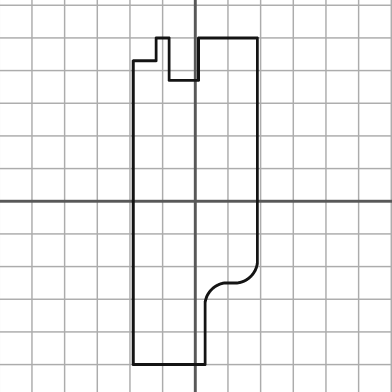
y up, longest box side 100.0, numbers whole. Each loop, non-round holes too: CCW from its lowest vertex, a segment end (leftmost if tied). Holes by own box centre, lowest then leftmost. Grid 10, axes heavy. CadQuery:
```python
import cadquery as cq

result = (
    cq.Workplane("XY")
    .moveTo(-19.0, -50.0)
    .lineTo(3.0, -50.0)
    .lineTo(3.0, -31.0)
    .threePointArc((5.0, -27.0), (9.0, -25.0))
    .lineTo(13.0, -25.0)
    .threePointArc((17.0, -23.0), (19.0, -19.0))
    .lineTo(19.0, 50.0)
    .lineTo(1.0, 50.0)
    .lineTo(1.0, 37.0)
    .lineTo(-8.0, 37.0)
    .lineTo(-8.0, 50.0)
    .lineTo(-12.0, 50.0)
    .lineTo(-12.0, 43.0)
    .lineTo(-19.0, 43.0)
    .close()
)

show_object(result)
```